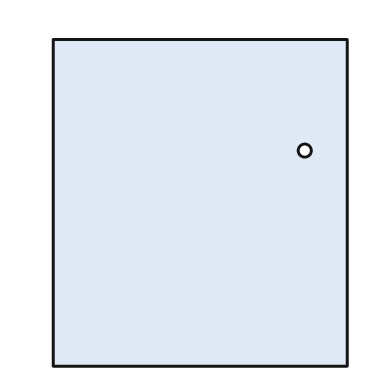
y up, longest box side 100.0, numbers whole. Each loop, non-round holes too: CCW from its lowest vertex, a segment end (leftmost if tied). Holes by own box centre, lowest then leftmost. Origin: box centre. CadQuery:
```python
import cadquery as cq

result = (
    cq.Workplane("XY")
    .moveTo(-45.0, -50.0)
    .lineTo(45.0, -50.0)
    .lineTo(45.0, 50.0)
    .lineTo(-45.0, 50.0)
    .close()
    .moveTo(32.0, 16.0)
    .circle(2.0)
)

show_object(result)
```